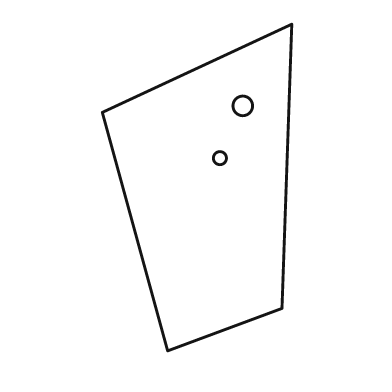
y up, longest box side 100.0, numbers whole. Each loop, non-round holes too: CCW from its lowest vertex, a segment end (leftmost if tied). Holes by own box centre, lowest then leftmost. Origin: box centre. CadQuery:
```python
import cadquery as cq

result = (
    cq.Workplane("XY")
    .moveTo(-9.0, -50.0)
    .lineTo(26.0, -37.0)
    .lineTo(29.0, 50.0)
    .lineTo(-29.0, 23.0)
    .close()
    .moveTo(7.0, 9.0)
    .circle(2.0)
    .moveTo(14.0, 25.0)
    .circle(3.0)
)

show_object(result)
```